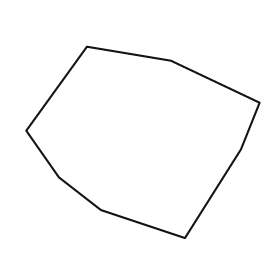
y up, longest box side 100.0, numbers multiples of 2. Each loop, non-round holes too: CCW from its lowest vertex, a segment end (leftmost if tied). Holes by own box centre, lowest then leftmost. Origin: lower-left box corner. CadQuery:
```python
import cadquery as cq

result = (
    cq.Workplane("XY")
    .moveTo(68.0, 0.0)
    .lineTo(92.0, 38.0)
    .lineTo(100.0, 58.0)
    .lineTo(62.0, 76.0)
    .lineTo(26.0, 82.0)
    .lineTo(0.0, 46.0)
    .lineTo(14.0, 26.0)
    .lineTo(32.0, 12.0)
    .close()
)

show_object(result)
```